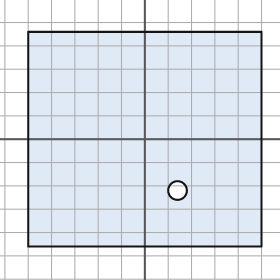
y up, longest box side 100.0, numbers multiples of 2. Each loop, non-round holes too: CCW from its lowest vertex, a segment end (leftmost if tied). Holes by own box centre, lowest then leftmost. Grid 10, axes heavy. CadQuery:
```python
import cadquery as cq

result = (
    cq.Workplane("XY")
    .moveTo(-50.0, -46.0)
    .lineTo(50.0, -46.0)
    .lineTo(50.0, 46.0)
    .lineTo(-50.0, 46.0)
    .close()
    .moveTo(14.0, -22.0)
    .circle(4.0)
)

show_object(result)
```